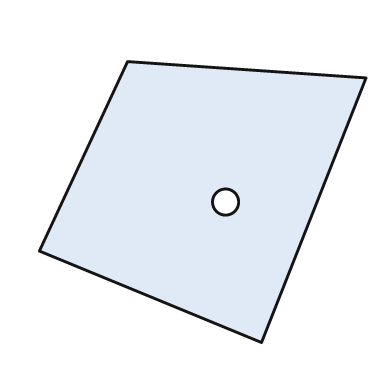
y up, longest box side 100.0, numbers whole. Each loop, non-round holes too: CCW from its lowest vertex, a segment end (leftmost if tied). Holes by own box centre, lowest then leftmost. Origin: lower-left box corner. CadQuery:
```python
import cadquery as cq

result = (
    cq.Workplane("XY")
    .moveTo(68.0, 0.0)
    .lineTo(100.0, 81.0)
    .lineTo(27.0, 86.0)
    .lineTo(0.0, 28.0)
    .close()
    .moveTo(57.0, 43.0)
    .circle(4.0)
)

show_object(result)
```